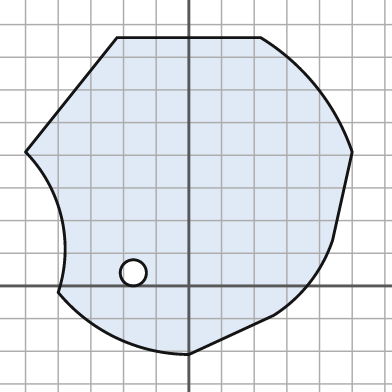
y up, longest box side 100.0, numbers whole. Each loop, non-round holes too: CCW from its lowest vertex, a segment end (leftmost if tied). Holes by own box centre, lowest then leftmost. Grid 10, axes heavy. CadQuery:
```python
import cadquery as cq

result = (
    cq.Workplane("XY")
    .moveTo(0.0, -21.0)
    .lineTo(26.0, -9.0)
    .threePointArc((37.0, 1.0), (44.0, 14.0))
    .lineTo(50.0, 41.0)
    .threePointArc((39.0, 61.0), (22.0, 76.0))
    .lineTo(-22.0, 76.0)
    .lineTo(-50.0, 41.0)
    .threePointArc((-39.0, 21.0), (-40.0, -2.0))
    .threePointArc((-22.0, -16.0), (0.0, -21.0))
    .close()
    .moveTo(-17.0, 4.0)
    .circle(4.0)
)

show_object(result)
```